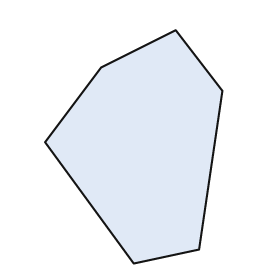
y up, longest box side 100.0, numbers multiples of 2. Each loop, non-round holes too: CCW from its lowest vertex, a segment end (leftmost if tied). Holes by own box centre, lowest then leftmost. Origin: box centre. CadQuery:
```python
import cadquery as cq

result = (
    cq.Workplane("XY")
    .moveTo(0.0, -50.0)
    .lineTo(28.0, -44.0)
    .lineTo(38.0, 24.0)
    .lineTo(18.0, 50.0)
    .lineTo(-14.0, 34.0)
    .lineTo(-38.0, 2.0)
    .close()
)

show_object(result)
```